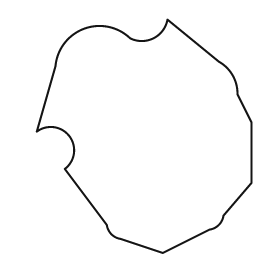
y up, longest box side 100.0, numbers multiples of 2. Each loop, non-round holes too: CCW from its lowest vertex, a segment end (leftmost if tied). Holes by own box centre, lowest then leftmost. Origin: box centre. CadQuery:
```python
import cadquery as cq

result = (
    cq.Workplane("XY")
    .moveTo(8.0, -50.0)
    .lineTo(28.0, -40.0)
    .threePointArc((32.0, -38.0), (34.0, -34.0))
    .lineTo(46.0, -20.0)
    .lineTo(46.0, 6.0)
    .lineTo(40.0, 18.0)
    .threePointArc((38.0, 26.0), (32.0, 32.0))
    .lineTo(10.0, 50.0)
    .threePointArc((4.0, 42.0), (-6.0, 42.0))
    .threePointArc((-26.0, 46.0), (-38.0, 30.0))
    .lineTo(-46.0, 2.0)
    .threePointArc((-32.0, 0.0), (-34.0, -14.0))
    .lineTo(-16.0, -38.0)
    .threePointArc((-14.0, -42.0), (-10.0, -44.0))
    .close()
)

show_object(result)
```